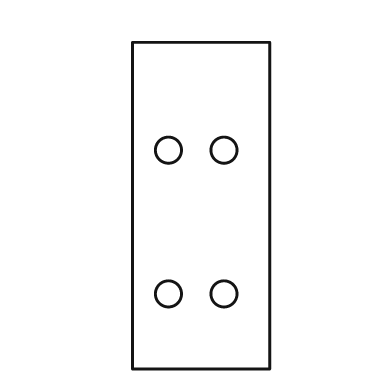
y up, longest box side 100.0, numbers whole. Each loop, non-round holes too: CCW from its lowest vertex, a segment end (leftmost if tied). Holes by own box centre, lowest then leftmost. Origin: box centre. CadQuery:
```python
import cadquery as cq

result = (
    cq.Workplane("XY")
    .moveTo(-21.0, -50.0)
    .lineTo(21.0, -50.0)
    .lineTo(21.0, 50.0)
    .lineTo(-21.0, 50.0)
    .close()
    .moveTo(-10.0, -27.0)
    .circle(4.0)
    .moveTo(7.0, -27.0)
    .circle(4.0)
    .moveTo(-10.0, 17.0)
    .circle(4.0)
    .moveTo(7.0, 17.0)
    .circle(4.0)
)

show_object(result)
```